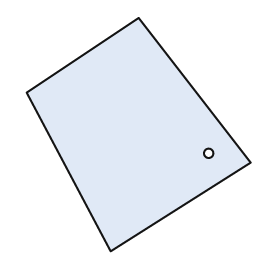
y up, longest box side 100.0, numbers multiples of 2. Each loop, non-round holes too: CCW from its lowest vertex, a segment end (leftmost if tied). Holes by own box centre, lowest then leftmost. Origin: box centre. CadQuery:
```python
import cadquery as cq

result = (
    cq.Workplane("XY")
    .moveTo(-12.0, -50.0)
    .lineTo(48.0, -12.0)
    .lineTo(0.0, 50.0)
    .lineTo(-48.0, 18.0)
    .close()
    .moveTo(30.0, -8.0)
    .circle(2.0)
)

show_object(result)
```